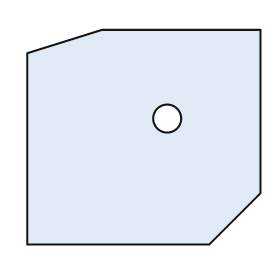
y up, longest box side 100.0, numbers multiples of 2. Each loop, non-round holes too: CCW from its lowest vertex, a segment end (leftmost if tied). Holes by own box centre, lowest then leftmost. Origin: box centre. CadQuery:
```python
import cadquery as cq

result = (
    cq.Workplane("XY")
    .moveTo(-50.0, -46.0)
    .lineTo(28.0, -46.0)
    .lineTo(50.0, -24.0)
    .lineTo(50.0, 46.0)
    .lineTo(-18.0, 46.0)
    .lineTo(-50.0, 36.0)
    .close()
    .moveTo(10.0, 8.0)
    .circle(6.0)
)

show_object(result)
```